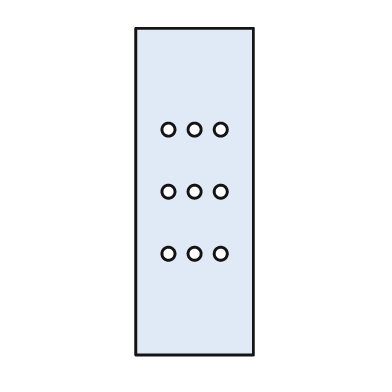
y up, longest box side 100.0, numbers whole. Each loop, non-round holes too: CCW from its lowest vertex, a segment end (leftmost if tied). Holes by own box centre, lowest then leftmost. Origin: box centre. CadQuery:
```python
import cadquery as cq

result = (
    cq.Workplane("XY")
    .moveTo(-18.0, -50.0)
    .lineTo(18.0, -50.0)
    .lineTo(18.0, 50.0)
    .lineTo(-18.0, 50.0)
    .close()
    .moveTo(-8.0, -19.0)
    .circle(2.0)
    .moveTo(0.0, -19.0)
    .circle(2.0)
    .moveTo(8.0, -19.0)
    .circle(2.0)
    .moveTo(-8.0, 0.0)
    .circle(2.0)
    .moveTo(0.0, 0.0)
    .circle(2.0)
    .moveTo(8.0, 0.0)
    .circle(2.0)
    .moveTo(-8.0, 19.0)
    .circle(2.0)
    .moveTo(0.0, 19.0)
    .circle(2.0)
    .moveTo(8.0, 19.0)
    .circle(2.0)
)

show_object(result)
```